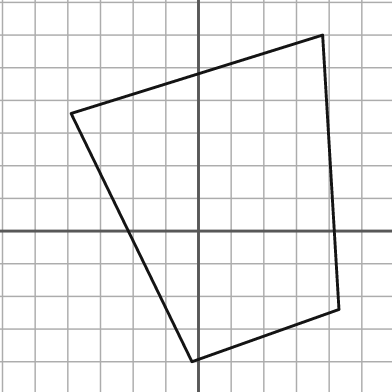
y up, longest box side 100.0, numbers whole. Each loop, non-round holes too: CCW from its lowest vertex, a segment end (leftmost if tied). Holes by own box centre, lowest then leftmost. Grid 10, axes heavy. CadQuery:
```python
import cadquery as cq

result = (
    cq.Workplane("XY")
    .moveTo(-2.0, -40.0)
    .lineTo(43.0, -24.0)
    .lineTo(38.0, 60.0)
    .lineTo(-39.0, 36.0)
    .close()
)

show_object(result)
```